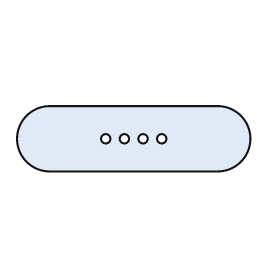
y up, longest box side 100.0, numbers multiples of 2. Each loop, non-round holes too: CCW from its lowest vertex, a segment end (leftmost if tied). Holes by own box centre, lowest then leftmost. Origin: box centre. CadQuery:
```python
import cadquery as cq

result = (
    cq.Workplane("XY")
    .moveTo(-36.0, -14.0)
    .lineTo(36.0, -14.0)
    .threePointArc((50.0, 0.0), (36.0, 14.0))
    .lineTo(-36.0, 14.0)
    .threePointArc((-50.0, 0.0), (-36.0, -14.0))
    .close()
    .moveTo(-12.0, 0.0)
    .circle(2.0)
    .moveTo(-4.0, 0.0)
    .circle(2.0)
    .moveTo(4.0, 0.0)
    .circle(2.0)
    .moveTo(12.0, 0.0)
    .circle(2.0)
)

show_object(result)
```